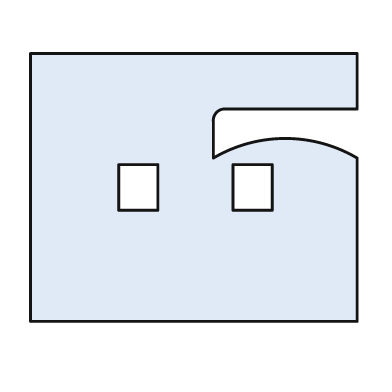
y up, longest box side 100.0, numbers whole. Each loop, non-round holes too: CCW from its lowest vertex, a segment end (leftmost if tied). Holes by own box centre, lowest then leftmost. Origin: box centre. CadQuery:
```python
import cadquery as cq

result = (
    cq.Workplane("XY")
    .moveTo(-50.0, -41.0)
    .lineTo(50.0, -41.0)
    .lineTo(50.0, 9.0)
    .threePointArc((28.0, 15.0), (6.0, 9.0))
    .lineTo(6.0, 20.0)
    .threePointArc((7.0, 23.0), (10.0, 24.0))
    .lineTo(50.0, 24.0)
    .lineTo(50.0, 41.0)
    .lineTo(-50.0, 41.0)
    .close()
    .moveTo(-23.0, -7.0)
    .lineTo(-11.0, -7.0)
    .lineTo(-11.0, 7.0)
    .lineTo(-23.0, 7.0)
    .close()
    .moveTo(12.0, -7.0)
    .lineTo(24.0, -7.0)
    .lineTo(24.0, 7.0)
    .lineTo(12.0, 7.0)
    .close()
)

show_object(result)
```